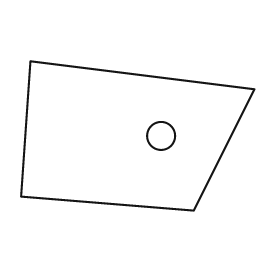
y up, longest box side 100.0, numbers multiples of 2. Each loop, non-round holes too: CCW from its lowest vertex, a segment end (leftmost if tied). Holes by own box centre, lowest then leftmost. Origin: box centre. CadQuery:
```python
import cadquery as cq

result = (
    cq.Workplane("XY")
    .moveTo(24.0, -32.0)
    .lineTo(50.0, 20.0)
    .lineTo(-46.0, 32.0)
    .lineTo(-50.0, -26.0)
    .close()
    .moveTo(10.0, 0.0)
    .circle(6.0)
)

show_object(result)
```